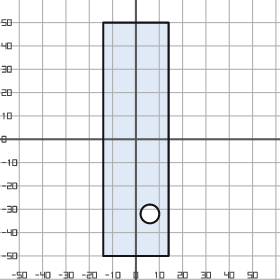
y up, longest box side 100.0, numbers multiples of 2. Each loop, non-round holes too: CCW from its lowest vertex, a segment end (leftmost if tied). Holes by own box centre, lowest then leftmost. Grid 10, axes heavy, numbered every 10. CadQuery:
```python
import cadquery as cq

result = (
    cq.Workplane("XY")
    .moveTo(-14.0, -50.0)
    .lineTo(14.0, -50.0)
    .lineTo(14.0, 50.0)
    .lineTo(-14.0, 50.0)
    .close()
    .moveTo(6.0, -32.0)
    .circle(4.0)
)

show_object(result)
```